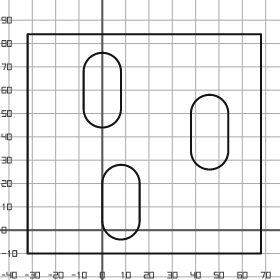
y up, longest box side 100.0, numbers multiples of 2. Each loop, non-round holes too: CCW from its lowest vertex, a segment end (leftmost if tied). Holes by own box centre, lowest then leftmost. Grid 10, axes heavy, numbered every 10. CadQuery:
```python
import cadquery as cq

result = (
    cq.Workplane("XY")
    .moveTo(-32.0, -10.0)
    .lineTo(68.0, -10.0)
    .lineTo(68.0, 84.0)
    .lineTo(-32.0, 84.0)
    .close()
    .moveTo(0.0, 4.0)
    .threePointArc((8.0, -4.0), (16.0, 4.0))
    .lineTo(16.0, 20.0)
    .threePointArc((8.0, 28.0), (0.0, 20.0))
    .close()
    .moveTo(38.0, 34.0)
    .threePointArc((46.0, 26.0), (54.0, 34.0))
    .lineTo(54.0, 50.0)
    .threePointArc((46.0, 58.0), (38.0, 50.0))
    .close()
    .moveTo(-8.0, 52.0)
    .threePointArc((0.0, 44.0), (8.0, 52.0))
    .lineTo(8.0, 68.0)
    .threePointArc((0.0, 76.0), (-8.0, 68.0))
    .close()
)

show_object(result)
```